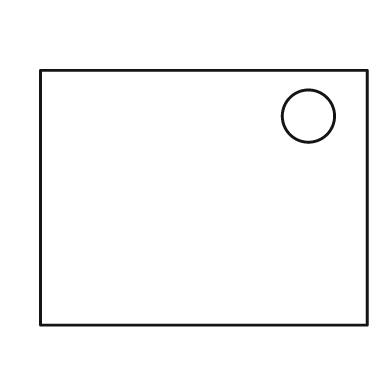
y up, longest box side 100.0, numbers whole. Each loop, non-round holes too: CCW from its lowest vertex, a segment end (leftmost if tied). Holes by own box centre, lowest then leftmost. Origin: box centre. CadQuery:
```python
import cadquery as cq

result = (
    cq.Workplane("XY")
    .moveTo(-50.0, -39.0)
    .lineTo(50.0, -39.0)
    .lineTo(50.0, 39.0)
    .lineTo(-50.0, 39.0)
    .close()
    .moveTo(32.0, 25.0)
    .circle(8.0)
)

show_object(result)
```